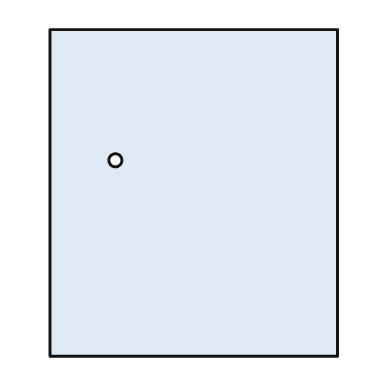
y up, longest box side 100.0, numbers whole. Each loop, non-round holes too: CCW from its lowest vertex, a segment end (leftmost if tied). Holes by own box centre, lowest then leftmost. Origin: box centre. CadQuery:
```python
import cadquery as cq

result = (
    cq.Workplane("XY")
    .moveTo(-44.0, -50.0)
    .lineTo(44.0, -50.0)
    .lineTo(44.0, 50.0)
    .lineTo(-44.0, 50.0)
    .close()
    .moveTo(-24.0, 10.0)
    .circle(2.0)
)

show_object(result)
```